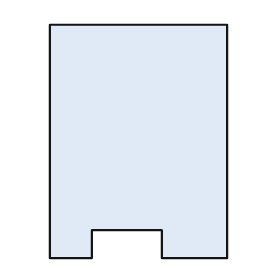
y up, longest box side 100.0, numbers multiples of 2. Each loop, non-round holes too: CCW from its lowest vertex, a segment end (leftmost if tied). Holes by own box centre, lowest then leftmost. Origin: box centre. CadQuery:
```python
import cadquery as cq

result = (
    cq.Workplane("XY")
    .moveTo(-38.0, -50.0)
    .lineTo(-20.0, -50.0)
    .lineTo(-20.0, -38.0)
    .lineTo(10.0, -38.0)
    .lineTo(10.0, -50.0)
    .lineTo(38.0, -50.0)
    .lineTo(38.0, 50.0)
    .lineTo(-38.0, 50.0)
    .close()
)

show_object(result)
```